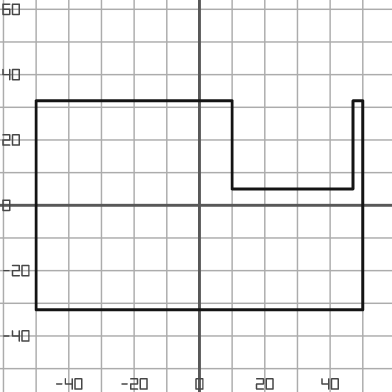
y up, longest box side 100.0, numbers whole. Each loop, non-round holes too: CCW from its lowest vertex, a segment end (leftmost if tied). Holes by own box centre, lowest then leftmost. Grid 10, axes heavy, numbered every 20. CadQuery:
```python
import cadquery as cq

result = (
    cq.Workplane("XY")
    .moveTo(-50.0, -32.0)
    .lineTo(50.0, -32.0)
    .lineTo(50.0, 32.0)
    .lineTo(47.0, 32.0)
    .lineTo(47.0, 5.0)
    .lineTo(10.0, 5.0)
    .lineTo(10.0, 32.0)
    .lineTo(-50.0, 32.0)
    .close()
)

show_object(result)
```